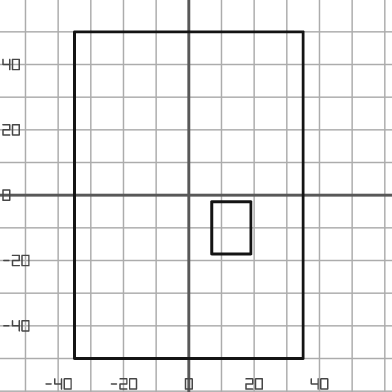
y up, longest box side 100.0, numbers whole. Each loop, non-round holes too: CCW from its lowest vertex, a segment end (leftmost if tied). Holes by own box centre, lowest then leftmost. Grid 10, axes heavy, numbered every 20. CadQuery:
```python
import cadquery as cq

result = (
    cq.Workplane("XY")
    .moveTo(-35.0, -50.0)
    .lineTo(35.0, -50.0)
    .lineTo(35.0, 50.0)
    .lineTo(-35.0, 50.0)
    .close()
    .moveTo(7.0, -18.0)
    .lineTo(19.0, -18.0)
    .lineTo(19.0, -2.0)
    .lineTo(7.0, -2.0)
    .close()
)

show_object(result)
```